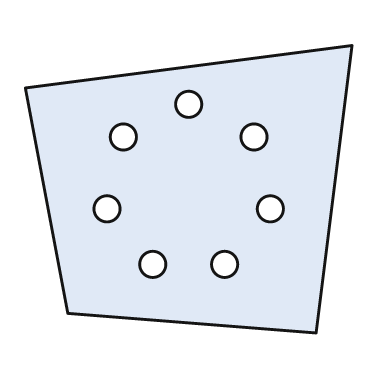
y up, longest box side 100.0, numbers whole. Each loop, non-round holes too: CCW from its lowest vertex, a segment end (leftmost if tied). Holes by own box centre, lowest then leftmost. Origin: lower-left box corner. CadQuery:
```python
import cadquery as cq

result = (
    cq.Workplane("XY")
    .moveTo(89.0, 0.0)
    .lineTo(100.0, 88.0)
    .lineTo(0.0, 75.0)
    .lineTo(13.0, 6.0)
    .close()
    .moveTo(39.0, 21.0)
    .circle(4.0)
    .moveTo(61.0, 21.0)
    .circle(4.0)
    .moveTo(25.0, 38.0)
    .circle(4.0)
    .moveTo(75.0, 38.0)
    .circle(4.0)
    .moveTo(30.0, 60.0)
    .circle(4.0)
    .moveTo(70.0, 60.0)
    .circle(4.0)
    .moveTo(50.0, 70.0)
    .circle(4.0)
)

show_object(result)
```